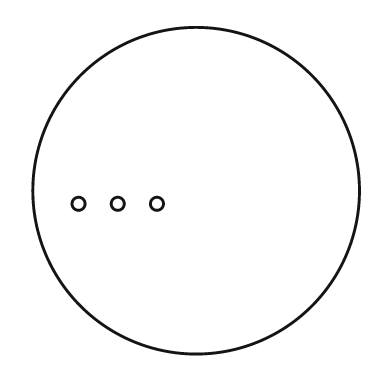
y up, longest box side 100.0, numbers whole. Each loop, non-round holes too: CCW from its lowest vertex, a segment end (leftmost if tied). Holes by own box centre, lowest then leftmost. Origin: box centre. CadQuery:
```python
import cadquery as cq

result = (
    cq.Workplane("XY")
    .moveTo(0.0, 0.0)
    .circle(50.0)
    .moveTo(-36.0, -4.0)
    .circle(2.0)
    .moveTo(-24.0, -4.0)
    .circle(2.0)
    .moveTo(-12.0, -4.0)
    .circle(2.0)
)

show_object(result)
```